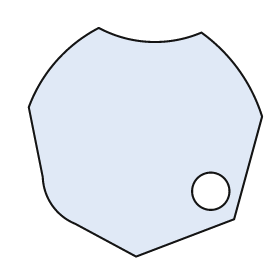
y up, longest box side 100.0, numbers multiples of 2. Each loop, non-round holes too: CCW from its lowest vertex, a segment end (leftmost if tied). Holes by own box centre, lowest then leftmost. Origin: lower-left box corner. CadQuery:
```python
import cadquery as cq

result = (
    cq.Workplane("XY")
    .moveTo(46.0, 0.0)
    .lineTo(88.0, 16.0)
    .lineTo(100.0, 60.0)
    .threePointArc((90.0, 80.0), (74.0, 96.0))
    .threePointArc((52.0, 92.0), (30.0, 98.0))
    .threePointArc((12.0, 84.0), (0.0, 64.0))
    .lineTo(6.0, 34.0)
    .threePointArc((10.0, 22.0), (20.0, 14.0))
    .close()
    .moveTo(78.0, 28.0)
    .circle(8.0)
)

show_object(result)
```